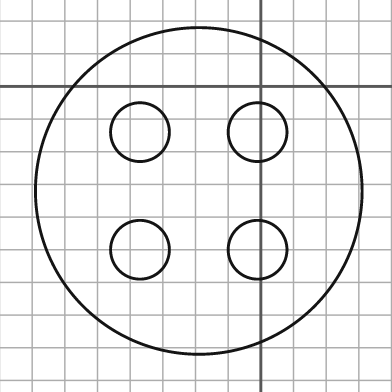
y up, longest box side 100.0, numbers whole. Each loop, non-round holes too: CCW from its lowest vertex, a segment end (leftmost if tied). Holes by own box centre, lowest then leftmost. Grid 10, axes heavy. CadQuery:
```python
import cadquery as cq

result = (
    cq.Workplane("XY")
    .moveTo(-19.0, -32.0)
    .circle(50.0)
    .moveTo(-37.0, -50.0)
    .circle(9.0)
    .moveTo(-1.0, -50.0)
    .circle(9.0)
    .moveTo(-37.0, -14.0)
    .circle(9.0)
    .moveTo(-1.0, -14.0)
    .circle(9.0)
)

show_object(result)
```